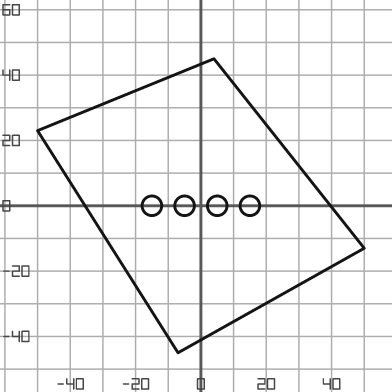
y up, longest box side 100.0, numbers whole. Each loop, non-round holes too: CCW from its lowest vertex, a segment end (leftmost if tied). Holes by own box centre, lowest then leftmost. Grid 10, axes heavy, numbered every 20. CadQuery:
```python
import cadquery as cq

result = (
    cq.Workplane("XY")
    .moveTo(-7.0, -45.0)
    .lineTo(50.0, -13.0)
    .lineTo(4.0, 45.0)
    .lineTo(-50.0, 23.0)
    .close()
    .moveTo(-15.0, 0.0)
    .circle(3.0)
    .moveTo(-5.0, 0.0)
    .circle(3.0)
    .moveTo(5.0, 0.0)
    .circle(3.0)
    .moveTo(15.0, 0.0)
    .circle(3.0)
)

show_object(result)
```